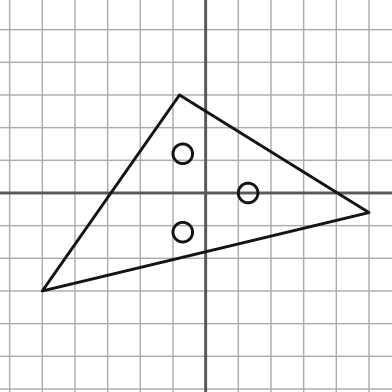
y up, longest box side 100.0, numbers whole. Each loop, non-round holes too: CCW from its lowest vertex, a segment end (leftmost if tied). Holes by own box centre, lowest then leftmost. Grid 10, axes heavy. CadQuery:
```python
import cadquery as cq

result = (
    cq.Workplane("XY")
    .moveTo(-50.0, -30.0)
    .lineTo(50.0, -6.0)
    .lineTo(-8.0, 30.0)
    .close()
    .moveTo(-7.0, -12.0)
    .circle(3.0)
    .moveTo(13.0, 0.0)
    .circle(3.0)
    .moveTo(-7.0, 12.0)
    .circle(3.0)
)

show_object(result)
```